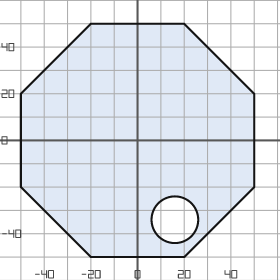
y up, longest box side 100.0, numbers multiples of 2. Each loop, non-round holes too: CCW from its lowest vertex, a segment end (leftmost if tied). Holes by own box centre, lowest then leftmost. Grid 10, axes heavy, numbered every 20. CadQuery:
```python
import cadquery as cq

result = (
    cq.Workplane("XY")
    .moveTo(-20.0, -50.0)
    .lineTo(20.0, -50.0)
    .lineTo(50.0, -20.0)
    .lineTo(50.0, 20.0)
    .lineTo(20.0, 50.0)
    .lineTo(-20.0, 50.0)
    .lineTo(-50.0, 20.0)
    .lineTo(-50.0, -20.0)
    .close()
    .moveTo(16.0, -34.0)
    .circle(10.0)
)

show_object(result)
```